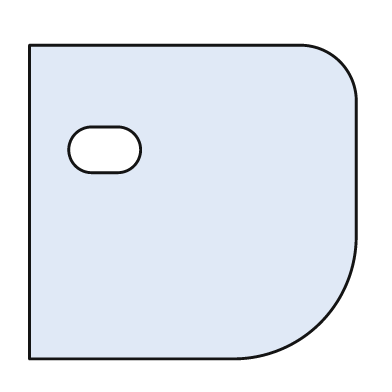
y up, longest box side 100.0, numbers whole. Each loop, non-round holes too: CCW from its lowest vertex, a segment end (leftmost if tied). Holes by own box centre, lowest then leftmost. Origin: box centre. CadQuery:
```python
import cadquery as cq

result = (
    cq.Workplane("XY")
    .moveTo(-50.0, -48.0)
    .lineTo(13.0, -48.0)
    .threePointArc((39.0, -37.0), (50.0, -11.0))
    .lineTo(50.0, 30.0)
    .threePointArc((45.0, 43.0), (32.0, 48.0))
    .lineTo(-50.0, 48.0)
    .close()
    .moveTo(-31.0, 9.0)
    .lineTo(-23.0, 9.0)
    .threePointArc((-16.0, 16.0), (-23.0, 23.0))
    .lineTo(-31.0, 23.0)
    .threePointArc((-38.0, 16.0), (-31.0, 9.0))
    .close()
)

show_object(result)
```